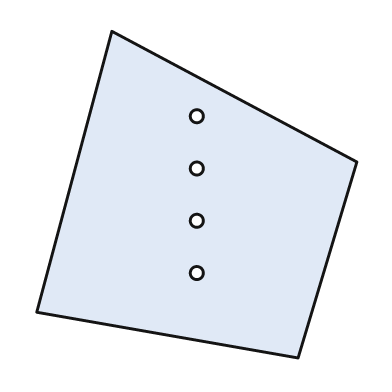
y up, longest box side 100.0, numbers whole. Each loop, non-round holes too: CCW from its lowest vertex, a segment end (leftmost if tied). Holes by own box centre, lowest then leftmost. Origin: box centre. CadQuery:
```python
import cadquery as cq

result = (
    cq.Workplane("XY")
    .moveTo(31.0, -50.0)
    .lineTo(49.0, 10.0)
    .lineTo(-26.0, 50.0)
    .lineTo(-49.0, -36.0)
    .close()
    .moveTo(0.0, -24.0)
    .circle(2.0)
    .moveTo(0.0, -8.0)
    .circle(2.0)
    .moveTo(0.0, 8.0)
    .circle(2.0)
    .moveTo(0.0, 24.0)
    .circle(2.0)
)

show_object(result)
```